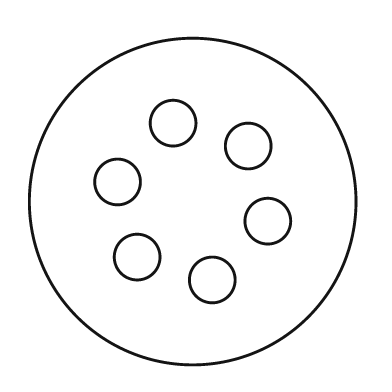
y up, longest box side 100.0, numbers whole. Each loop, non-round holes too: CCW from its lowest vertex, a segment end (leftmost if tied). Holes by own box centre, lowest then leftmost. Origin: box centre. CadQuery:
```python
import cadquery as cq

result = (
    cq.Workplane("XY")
    .moveTo(0.0, 0.0)
    .circle(50.0)
    .moveTo(6.0, -24.0)
    .circle(7.0)
    .moveTo(-17.0, -17.0)
    .circle(7.0)
    .moveTo(23.0, -6.0)
    .circle(7.0)
    .moveTo(-23.0, 6.0)
    .circle(7.0)
    .moveTo(17.0, 17.0)
    .circle(7.0)
    .moveTo(-6.0, 24.0)
    .circle(7.0)
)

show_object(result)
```